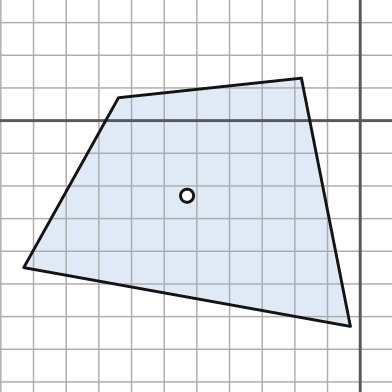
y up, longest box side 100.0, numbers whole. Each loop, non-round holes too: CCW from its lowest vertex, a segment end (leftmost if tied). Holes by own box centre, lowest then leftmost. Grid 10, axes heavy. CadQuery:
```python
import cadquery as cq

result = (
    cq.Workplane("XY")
    .moveTo(-3.0, -63.0)
    .lineTo(-18.0, 13.0)
    .lineTo(-74.0, 7.0)
    .lineTo(-103.0, -45.0)
    .close()
    .moveTo(-53.0, -23.0)
    .circle(2.0)
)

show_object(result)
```